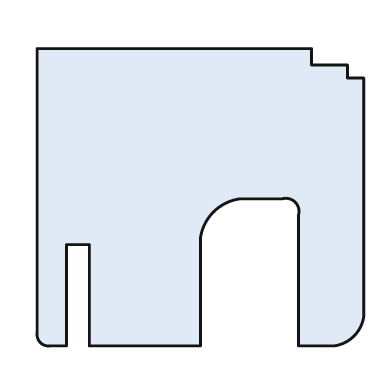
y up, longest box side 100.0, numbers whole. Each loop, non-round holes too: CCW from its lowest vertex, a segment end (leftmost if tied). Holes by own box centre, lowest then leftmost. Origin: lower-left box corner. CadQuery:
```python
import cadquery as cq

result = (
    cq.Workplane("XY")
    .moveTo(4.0, 0.0)
    .lineTo(9.0, 0.0)
    .lineTo(9.0, 31.0)
    .lineTo(16.0, 31.0)
    .lineTo(16.0, 0.0)
    .lineTo(50.0, 0.0)
    .lineTo(50.0, 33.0)
    .threePointArc((54.0, 41.0), (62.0, 45.0))
    .lineTo(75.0, 45.0)
    .threePointArc((79.0, 44.0), (80.0, 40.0))
    .lineTo(80.0, 0.0)
    .lineTo(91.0, 0.0)
    .threePointArc((97.0, 3.0), (100.0, 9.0))
    .lineTo(100.0, 82.0)
    .lineTo(95.0, 82.0)
    .lineTo(95.0, 86.0)
    .lineTo(84.0, 86.0)
    .lineTo(84.0, 91.0)
    .lineTo(0.0, 91.0)
    .lineTo(0.0, 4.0)
    .threePointArc((1.0, 1.0), (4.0, 0.0))
    .close()
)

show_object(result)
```